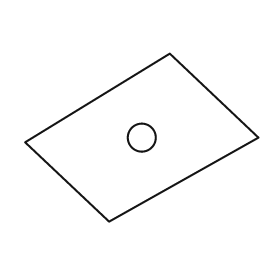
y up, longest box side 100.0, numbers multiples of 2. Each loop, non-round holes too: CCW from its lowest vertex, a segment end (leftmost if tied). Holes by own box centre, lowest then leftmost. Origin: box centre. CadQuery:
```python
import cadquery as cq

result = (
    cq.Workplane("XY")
    .moveTo(-14.0, -36.0)
    .lineTo(50.0, 0.0)
    .lineTo(12.0, 36.0)
    .lineTo(-50.0, -2.0)
    .close()
    .moveTo(0.0, 0.0)
    .circle(6.0)
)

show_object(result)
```